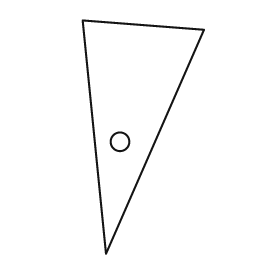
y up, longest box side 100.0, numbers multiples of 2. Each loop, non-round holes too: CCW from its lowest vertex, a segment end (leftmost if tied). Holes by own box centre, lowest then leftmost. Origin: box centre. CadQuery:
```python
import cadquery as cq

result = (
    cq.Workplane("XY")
    .moveTo(-16.0, -50.0)
    .lineTo(26.0, 46.0)
    .lineTo(-26.0, 50.0)
    .close()
    .moveTo(-10.0, -2.0)
    .circle(4.0)
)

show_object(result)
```